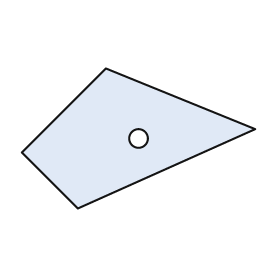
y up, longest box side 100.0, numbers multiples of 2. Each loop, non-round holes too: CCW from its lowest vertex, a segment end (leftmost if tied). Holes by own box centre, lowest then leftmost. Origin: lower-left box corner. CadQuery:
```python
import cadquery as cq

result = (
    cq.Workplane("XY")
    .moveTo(24.0, 0.0)
    .lineTo(100.0, 34.0)
    .lineTo(36.0, 60.0)
    .lineTo(0.0, 24.0)
    .close()
    .moveTo(50.0, 30.0)
    .circle(4.0)
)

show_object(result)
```